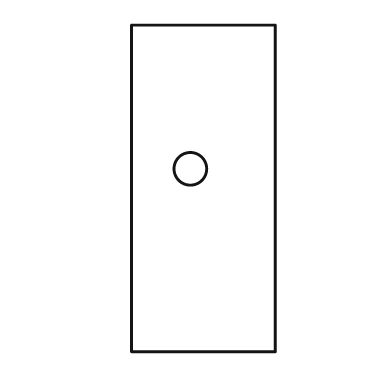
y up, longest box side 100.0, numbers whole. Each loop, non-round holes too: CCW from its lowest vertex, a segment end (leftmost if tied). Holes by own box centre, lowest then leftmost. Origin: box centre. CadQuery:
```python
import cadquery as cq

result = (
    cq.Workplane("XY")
    .moveTo(-22.0, -50.0)
    .lineTo(22.0, -50.0)
    .lineTo(22.0, 50.0)
    .lineTo(-22.0, 50.0)
    .close()
    .moveTo(-4.0, 6.0)
    .circle(5.0)
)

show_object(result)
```